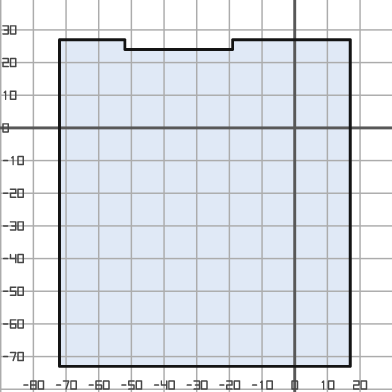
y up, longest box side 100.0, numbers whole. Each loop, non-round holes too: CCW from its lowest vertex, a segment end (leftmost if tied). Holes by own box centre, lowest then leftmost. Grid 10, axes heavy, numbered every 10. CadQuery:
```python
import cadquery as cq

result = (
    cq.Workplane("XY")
    .moveTo(-72.0, -73.0)
    .lineTo(17.0, -73.0)
    .lineTo(17.0, 27.0)
    .lineTo(-19.0, 27.0)
    .lineTo(-19.0, 24.0)
    .lineTo(-52.0, 24.0)
    .lineTo(-52.0, 27.0)
    .lineTo(-72.0, 27.0)
    .close()
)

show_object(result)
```